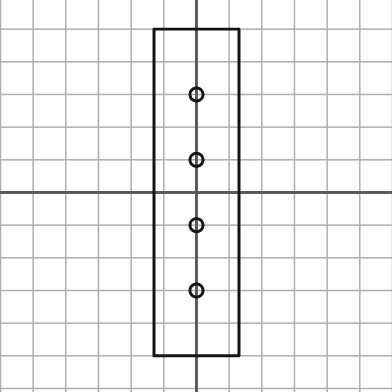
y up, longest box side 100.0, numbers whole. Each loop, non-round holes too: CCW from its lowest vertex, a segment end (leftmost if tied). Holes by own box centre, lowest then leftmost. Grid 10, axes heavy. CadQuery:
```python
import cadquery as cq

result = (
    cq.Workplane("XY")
    .moveTo(-13.0, -50.0)
    .lineTo(13.0, -50.0)
    .lineTo(13.0, 50.0)
    .lineTo(-13.0, 50.0)
    .close()
    .moveTo(0.0, -30.0)
    .circle(2.0)
    .moveTo(0.0, -10.0)
    .circle(2.0)
    .moveTo(0.0, 10.0)
    .circle(2.0)
    .moveTo(0.0, 30.0)
    .circle(2.0)
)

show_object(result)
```